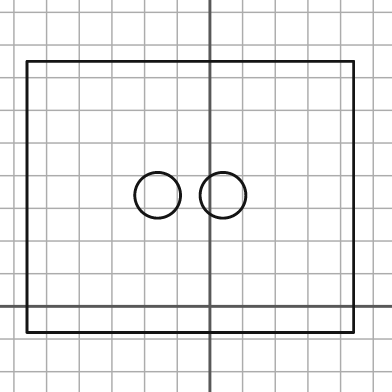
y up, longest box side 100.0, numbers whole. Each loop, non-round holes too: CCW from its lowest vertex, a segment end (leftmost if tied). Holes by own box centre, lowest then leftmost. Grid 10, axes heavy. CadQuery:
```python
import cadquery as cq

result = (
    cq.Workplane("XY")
    .moveTo(-56.0, -8.0)
    .lineTo(44.0, -8.0)
    .lineTo(44.0, 75.0)
    .lineTo(-56.0, 75.0)
    .close()
    .moveTo(-16.0, 34.0)
    .circle(7.0)
    .moveTo(4.0, 34.0)
    .circle(7.0)
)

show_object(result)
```